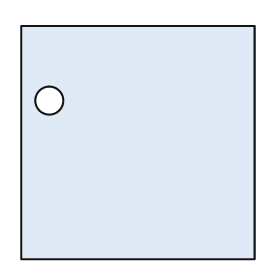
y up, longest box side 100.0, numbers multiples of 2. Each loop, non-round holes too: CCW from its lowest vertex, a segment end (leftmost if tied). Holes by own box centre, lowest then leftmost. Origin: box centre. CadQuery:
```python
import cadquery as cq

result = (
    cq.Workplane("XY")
    .moveTo(-50.0, -50.0)
    .lineTo(50.0, -50.0)
    .lineTo(50.0, 50.0)
    .lineTo(-50.0, 50.0)
    .close()
    .moveTo(-38.0, 18.0)
    .circle(6.0)
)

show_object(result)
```